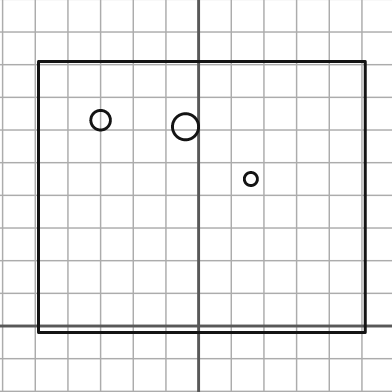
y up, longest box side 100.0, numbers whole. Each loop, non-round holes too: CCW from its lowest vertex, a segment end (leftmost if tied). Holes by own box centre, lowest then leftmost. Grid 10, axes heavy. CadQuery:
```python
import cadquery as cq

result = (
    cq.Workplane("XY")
    .moveTo(-49.0, -2.0)
    .lineTo(51.0, -2.0)
    .lineTo(51.0, 81.0)
    .lineTo(-49.0, 81.0)
    .close()
    .moveTo(16.0, 45.0)
    .circle(2.0)
    .moveTo(-4.0, 61.0)
    .circle(4.0)
    .moveTo(-30.0, 63.0)
    .circle(3.0)
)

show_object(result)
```